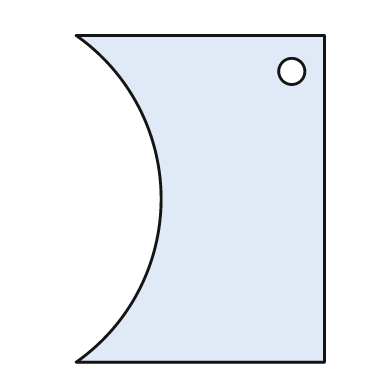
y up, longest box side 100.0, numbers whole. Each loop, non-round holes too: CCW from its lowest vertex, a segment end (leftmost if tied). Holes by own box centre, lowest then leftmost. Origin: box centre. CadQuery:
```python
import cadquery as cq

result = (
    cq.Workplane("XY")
    .moveTo(-38.0, -50.0)
    .lineTo(38.0, -50.0)
    .lineTo(38.0, 50.0)
    .lineTo(-38.0, 50.0)
    .threePointArc((-12.0, 0.0), (-38.0, -50.0))
    .close()
    .moveTo(28.0, 39.0)
    .circle(4.0)
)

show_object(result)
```